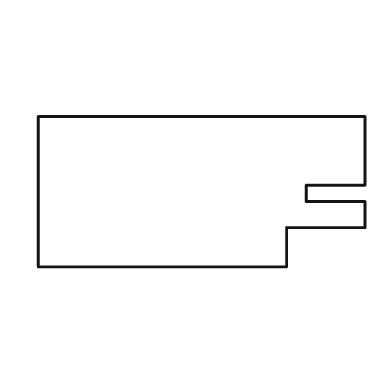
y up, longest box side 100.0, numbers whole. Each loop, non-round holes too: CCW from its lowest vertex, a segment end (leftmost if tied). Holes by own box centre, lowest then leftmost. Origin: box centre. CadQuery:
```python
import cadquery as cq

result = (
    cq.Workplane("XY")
    .moveTo(-50.0, -23.0)
    .lineTo(26.0, -23.0)
    .lineTo(26.0, -11.0)
    .lineTo(50.0, -11.0)
    .lineTo(50.0, -3.0)
    .lineTo(32.0, -3.0)
    .lineTo(32.0, 2.0)
    .lineTo(50.0, 2.0)
    .lineTo(50.0, 23.0)
    .lineTo(-50.0, 23.0)
    .close()
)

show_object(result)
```